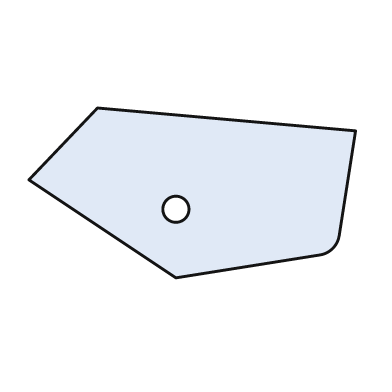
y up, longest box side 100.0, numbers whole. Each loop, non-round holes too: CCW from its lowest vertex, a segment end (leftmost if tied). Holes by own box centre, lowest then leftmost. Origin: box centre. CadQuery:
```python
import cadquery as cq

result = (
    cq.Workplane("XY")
    .moveTo(-5.0, -26.0)
    .lineTo(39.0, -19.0)
    .threePointArc((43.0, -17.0), (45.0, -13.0))
    .lineTo(50.0, 19.0)
    .lineTo(-29.0, 26.0)
    .lineTo(-50.0, 4.0)
    .close()
    .moveTo(-5.0, -5.0)
    .circle(4.0)
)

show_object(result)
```